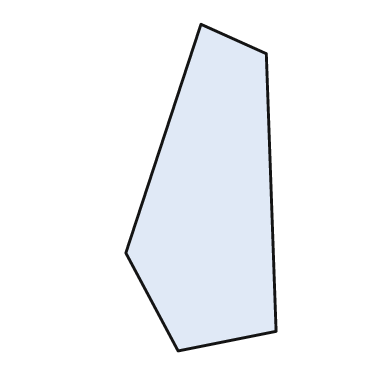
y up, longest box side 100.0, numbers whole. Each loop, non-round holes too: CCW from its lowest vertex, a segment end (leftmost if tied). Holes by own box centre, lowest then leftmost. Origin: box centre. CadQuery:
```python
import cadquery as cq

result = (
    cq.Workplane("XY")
    .moveTo(-7.0, -50.0)
    .lineTo(23.0, -44.0)
    .lineTo(20.0, 41.0)
    .lineTo(0.0, 50.0)
    .lineTo(-23.0, -20.0)
    .close()
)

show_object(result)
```